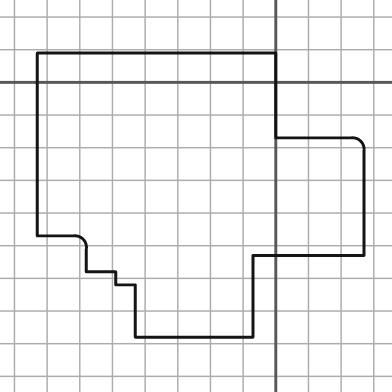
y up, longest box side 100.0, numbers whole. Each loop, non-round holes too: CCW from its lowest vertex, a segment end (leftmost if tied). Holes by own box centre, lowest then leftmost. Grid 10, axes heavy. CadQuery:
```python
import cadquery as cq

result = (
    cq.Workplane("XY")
    .moveTo(-43.0, -78.0)
    .lineTo(-7.0, -78.0)
    .lineTo(-7.0, -53.0)
    .lineTo(27.0, -53.0)
    .lineTo(27.0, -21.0)
    .threePointArc((26.0, -18.0), (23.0, -17.0))
    .lineTo(0.0, -17.0)
    .lineTo(0.0, 9.0)
    .lineTo(-73.0, 9.0)
    .lineTo(-73.0, -47.0)
    .lineTo(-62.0, -47.0)
    .threePointArc((-59.0, -48.0), (-58.0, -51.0))
    .lineTo(-58.0, -58.0)
    .lineTo(-49.0, -58.0)
    .lineTo(-49.0, -62.0)
    .lineTo(-43.0, -62.0)
    .close()
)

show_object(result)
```